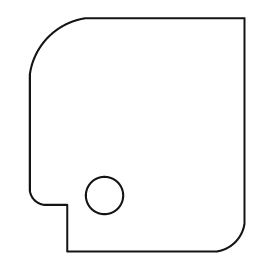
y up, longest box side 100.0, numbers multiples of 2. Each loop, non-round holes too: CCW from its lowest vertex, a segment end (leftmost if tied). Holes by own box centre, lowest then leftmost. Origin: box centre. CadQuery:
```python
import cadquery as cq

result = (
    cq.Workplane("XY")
    .moveTo(-30.0, -50.0)
    .lineTo(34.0, -50.0)
    .threePointArc((42.0, -46.0), (46.0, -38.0))
    .lineTo(46.0, 50.0)
    .lineTo(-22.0, 50.0)
    .threePointArc((-38.0, 42.0), (-46.0, 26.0))
    .lineTo(-46.0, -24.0)
    .threePointArc((-44.0, -28.0), (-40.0, -30.0))
    .lineTo(-30.0, -30.0)
    .close()
    .moveTo(-14.0, -26.0)
    .circle(8.0)
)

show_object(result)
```